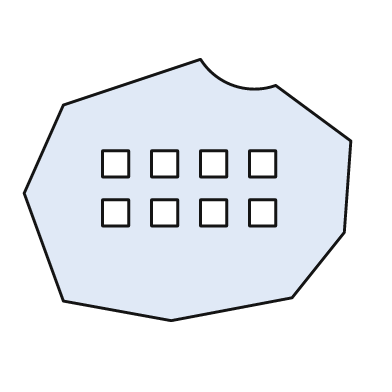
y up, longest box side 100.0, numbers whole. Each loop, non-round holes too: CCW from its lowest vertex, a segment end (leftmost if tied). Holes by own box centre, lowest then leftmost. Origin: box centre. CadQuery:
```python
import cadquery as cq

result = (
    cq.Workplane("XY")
    .moveTo(-5.0, -40.0)
    .lineTo(32.0, -33.0)
    .lineTo(48.0, -13.0)
    .lineTo(50.0, 15.0)
    .lineTo(27.0, 32.0)
    .threePointArc((14.0, 32.0), (4.0, 40.0))
    .lineTo(-38.0, 26.0)
    .lineTo(-50.0, -1.0)
    .lineTo(-38.0, -34.0)
    .close()
    .moveTo(-26.0, -11.0)
    .lineTo(-18.0, -11.0)
    .lineTo(-18.0, -3.0)
    .lineTo(-26.0, -3.0)
    .close()
    .moveTo(-11.0, -11.0)
    .lineTo(-3.0, -11.0)
    .lineTo(-3.0, -3.0)
    .lineTo(-11.0, -3.0)
    .close()
    .moveTo(4.0, -11.0)
    .lineTo(12.0, -11.0)
    .lineTo(12.0, -3.0)
    .lineTo(4.0, -3.0)
    .close()
    .moveTo(19.0, -11.0)
    .lineTo(27.0, -11.0)
    .lineTo(27.0, -3.0)
    .lineTo(19.0, -3.0)
    .close()
    .moveTo(-26.0, 4.0)
    .lineTo(-18.0, 4.0)
    .lineTo(-18.0, 12.0)
    .lineTo(-26.0, 12.0)
    .close()
    .moveTo(-11.0, 4.0)
    .lineTo(-3.0, 4.0)
    .lineTo(-3.0, 12.0)
    .lineTo(-11.0, 12.0)
    .close()
    .moveTo(4.0, 4.0)
    .lineTo(12.0, 4.0)
    .lineTo(12.0, 12.0)
    .lineTo(4.0, 12.0)
    .close()
    .moveTo(19.0, 4.0)
    .lineTo(27.0, 4.0)
    .lineTo(27.0, 12.0)
    .lineTo(19.0, 12.0)
    .close()
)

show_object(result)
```